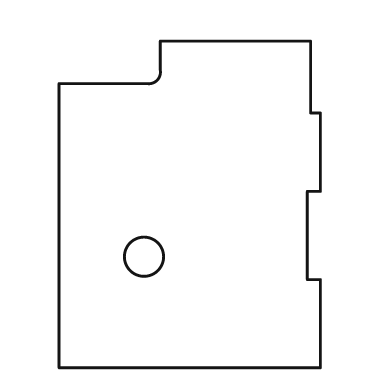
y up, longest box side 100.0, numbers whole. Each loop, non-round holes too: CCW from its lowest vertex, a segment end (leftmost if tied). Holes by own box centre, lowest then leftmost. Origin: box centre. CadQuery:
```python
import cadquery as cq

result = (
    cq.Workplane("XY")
    .moveTo(-40.0, -50.0)
    .lineTo(40.0, -50.0)
    .lineTo(40.0, -23.0)
    .lineTo(36.0, -23.0)
    .lineTo(36.0, 4.0)
    .lineTo(40.0, 4.0)
    .lineTo(40.0, 28.0)
    .lineTo(37.0, 28.0)
    .lineTo(37.0, 50.0)
    .lineTo(-9.0, 50.0)
    .lineTo(-9.0, 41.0)
    .threePointArc((-10.0, 38.0), (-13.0, 37.0))
    .lineTo(-40.0, 37.0)
    .close()
    .moveTo(-14.0, -16.0)
    .circle(6.0)
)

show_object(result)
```